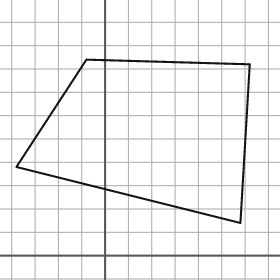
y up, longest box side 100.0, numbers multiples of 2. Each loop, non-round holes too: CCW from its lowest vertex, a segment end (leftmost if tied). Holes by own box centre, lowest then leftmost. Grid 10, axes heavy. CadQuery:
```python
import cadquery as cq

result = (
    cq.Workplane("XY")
    .moveTo(58.0, 14.0)
    .lineTo(62.0, 82.0)
    .lineTo(-8.0, 84.0)
    .lineTo(-38.0, 38.0)
    .close()
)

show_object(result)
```